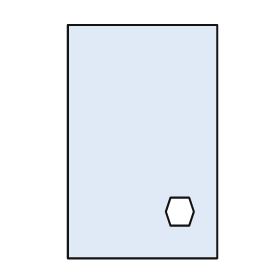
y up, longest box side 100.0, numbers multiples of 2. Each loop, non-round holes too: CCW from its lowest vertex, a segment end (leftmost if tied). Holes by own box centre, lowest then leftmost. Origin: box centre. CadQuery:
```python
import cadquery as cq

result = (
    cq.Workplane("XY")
    .moveTo(-32.0, -50.0)
    .lineTo(32.0, -50.0)
    .lineTo(32.0, 50.0)
    .lineTo(-32.0, 50.0)
    .close()
    .moveTo(12.0, -36.0)
    .lineTo(20.0, -36.0)
    .lineTo(22.0, -30.0)
    .lineTo(20.0, -24.0)
    .lineTo(12.0, -24.0)
    .lineTo(10.0, -30.0)
    .close()
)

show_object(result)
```